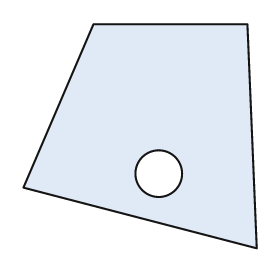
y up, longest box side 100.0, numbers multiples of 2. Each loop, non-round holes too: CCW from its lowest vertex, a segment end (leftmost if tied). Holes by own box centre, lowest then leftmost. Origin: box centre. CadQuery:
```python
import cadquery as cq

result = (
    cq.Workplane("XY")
    .moveTo(50.0, -48.0)
    .lineTo(46.0, 48.0)
    .lineTo(-20.0, 48.0)
    .lineTo(-50.0, -22.0)
    .close()
    .moveTo(8.0, -16.0)
    .circle(10.0)
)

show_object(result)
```